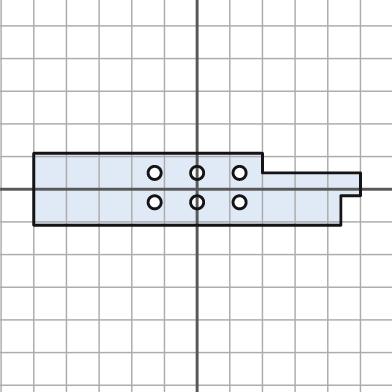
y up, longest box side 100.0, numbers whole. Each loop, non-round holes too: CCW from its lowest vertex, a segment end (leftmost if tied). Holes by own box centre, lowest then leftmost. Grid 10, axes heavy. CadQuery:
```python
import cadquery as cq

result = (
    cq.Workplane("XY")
    .moveTo(-50.0, -11.0)
    .lineTo(44.0, -11.0)
    .lineTo(44.0, -2.0)
    .lineTo(50.0, -2.0)
    .lineTo(50.0, 5.0)
    .lineTo(20.0, 5.0)
    .lineTo(20.0, 11.0)
    .lineTo(-50.0, 11.0)
    .close()
    .moveTo(-13.0, -4.0)
    .circle(2.0)
    .moveTo(0.0, -4.0)
    .circle(2.0)
    .moveTo(13.0, -4.0)
    .circle(2.0)
    .moveTo(-13.0, 5.0)
    .circle(2.0)
    .moveTo(0.0, 5.0)
    .circle(2.0)
    .moveTo(13.0, 5.0)
    .circle(2.0)
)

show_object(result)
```